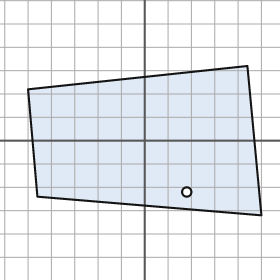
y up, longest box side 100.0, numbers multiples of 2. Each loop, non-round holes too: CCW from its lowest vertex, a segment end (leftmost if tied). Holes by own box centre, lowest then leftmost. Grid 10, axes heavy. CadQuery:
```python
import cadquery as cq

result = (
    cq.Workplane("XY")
    .moveTo(50.0, -32.0)
    .lineTo(44.0, 32.0)
    .lineTo(-50.0, 22.0)
    .lineTo(-46.0, -24.0)
    .close()
    .moveTo(18.0, -22.0)
    .circle(2.0)
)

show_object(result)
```